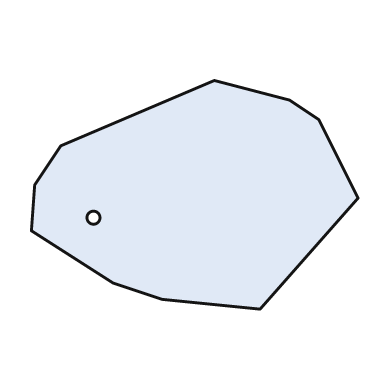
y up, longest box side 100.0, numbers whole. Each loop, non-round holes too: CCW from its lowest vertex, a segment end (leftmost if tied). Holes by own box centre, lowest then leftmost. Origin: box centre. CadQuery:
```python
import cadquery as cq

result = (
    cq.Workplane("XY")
    .moveTo(20.0, -35.0)
    .lineTo(50.0, -1.0)
    .lineTo(38.0, 23.0)
    .lineTo(29.0, 29.0)
    .lineTo(6.0, 35.0)
    .lineTo(-41.0, 15.0)
    .lineTo(-49.0, 3.0)
    .lineTo(-50.0, -11.0)
    .lineTo(-25.0, -27.0)
    .lineTo(-10.0, -32.0)
    .close()
    .moveTo(-31.0, -7.0)
    .circle(2.0)
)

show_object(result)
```